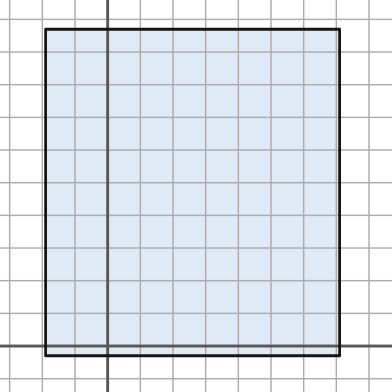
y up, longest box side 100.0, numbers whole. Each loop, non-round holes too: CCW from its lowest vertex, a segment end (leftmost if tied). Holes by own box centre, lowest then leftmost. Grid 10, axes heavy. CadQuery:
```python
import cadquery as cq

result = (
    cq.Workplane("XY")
    .moveTo(-19.0, -3.0)
    .lineTo(71.0, -3.0)
    .lineTo(71.0, 97.0)
    .lineTo(-19.0, 97.0)
    .close()
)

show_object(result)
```